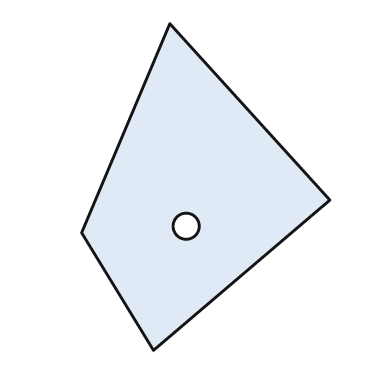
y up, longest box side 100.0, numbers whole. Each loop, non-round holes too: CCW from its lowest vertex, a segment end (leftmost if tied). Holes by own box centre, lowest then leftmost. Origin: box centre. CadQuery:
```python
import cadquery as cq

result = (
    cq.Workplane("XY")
    .moveTo(-16.0, -50.0)
    .lineTo(38.0, -4.0)
    .lineTo(-11.0, 50.0)
    .lineTo(-38.0, -14.0)
    .close()
    .moveTo(-6.0, -12.0)
    .circle(4.0)
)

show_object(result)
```